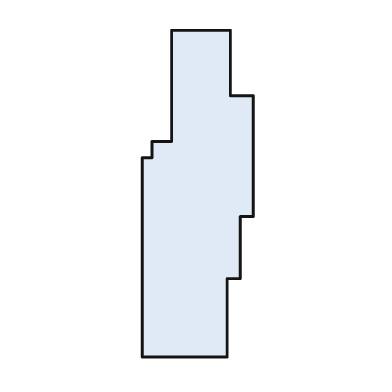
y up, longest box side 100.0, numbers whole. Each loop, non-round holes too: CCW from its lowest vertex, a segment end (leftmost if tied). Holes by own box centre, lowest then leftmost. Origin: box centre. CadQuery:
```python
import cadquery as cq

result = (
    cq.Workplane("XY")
    .moveTo(-17.0, -50.0)
    .lineTo(9.0, -50.0)
    .lineTo(9.0, -26.0)
    .lineTo(13.0, -26.0)
    .lineTo(13.0, -7.0)
    .lineTo(17.0, -7.0)
    .lineTo(17.0, 30.0)
    .lineTo(10.0, 30.0)
    .lineTo(10.0, 50.0)
    .lineTo(-8.0, 50.0)
    .lineTo(-8.0, 16.0)
    .lineTo(-14.0, 16.0)
    .lineTo(-14.0, 11.0)
    .lineTo(-17.0, 11.0)
    .close()
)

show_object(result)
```